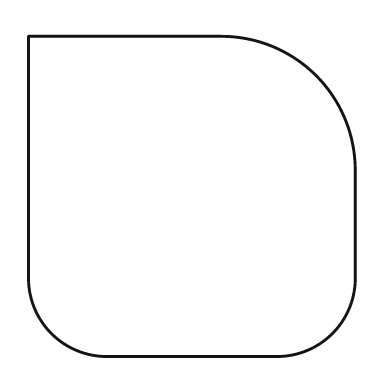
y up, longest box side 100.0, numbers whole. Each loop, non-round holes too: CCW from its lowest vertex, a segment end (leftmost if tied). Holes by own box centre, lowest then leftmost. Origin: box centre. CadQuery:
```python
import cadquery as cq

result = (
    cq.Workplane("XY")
    .moveTo(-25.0, -49.0)
    .lineTo(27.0, -49.0)
    .threePointArc((43.0, -42.0), (50.0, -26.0))
    .lineTo(50.0, 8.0)
    .threePointArc((38.0, 37.0), (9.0, 49.0))
    .lineTo(-50.0, 49.0)
    .lineTo(-50.0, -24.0)
    .threePointArc((-43.0, -42.0), (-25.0, -49.0))
    .close()
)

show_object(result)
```